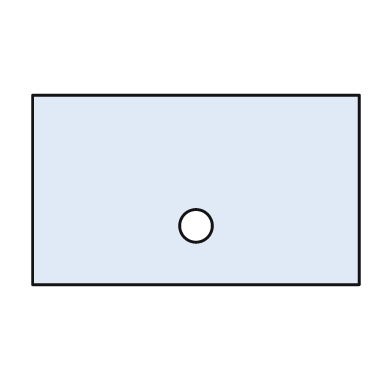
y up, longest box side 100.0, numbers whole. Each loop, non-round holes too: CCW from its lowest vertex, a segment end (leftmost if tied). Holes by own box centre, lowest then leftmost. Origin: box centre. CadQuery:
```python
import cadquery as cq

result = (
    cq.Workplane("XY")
    .moveTo(-50.0, -29.0)
    .lineTo(50.0, -29.0)
    .lineTo(50.0, 29.0)
    .lineTo(-50.0, 29.0)
    .close()
    .moveTo(0.0, -11.0)
    .circle(5.0)
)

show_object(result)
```